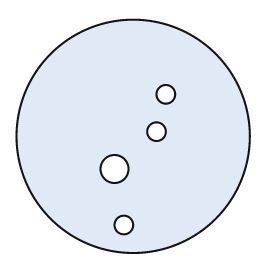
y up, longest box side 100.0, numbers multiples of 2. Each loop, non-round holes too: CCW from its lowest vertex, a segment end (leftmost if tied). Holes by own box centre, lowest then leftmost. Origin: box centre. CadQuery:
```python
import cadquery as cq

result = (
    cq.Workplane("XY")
    .moveTo(0.0, 0.0)
    .circle(50.0)
    .moveTo(-4.0, -38.0)
    .circle(4.0)
    .moveTo(-8.0, -14.0)
    .circle(6.0)
    .moveTo(10.0, 2.0)
    .circle(4.0)
    .moveTo(14.0, 18.0)
    .circle(4.0)
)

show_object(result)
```